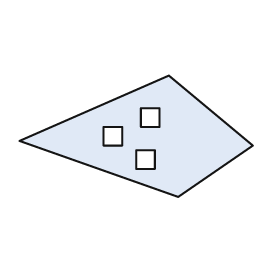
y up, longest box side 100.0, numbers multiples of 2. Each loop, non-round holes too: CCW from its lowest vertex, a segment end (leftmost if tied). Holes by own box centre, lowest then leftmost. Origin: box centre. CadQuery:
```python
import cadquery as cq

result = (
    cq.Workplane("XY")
    .moveTo(18.0, -26.0)
    .lineTo(50.0, -4.0)
    .lineTo(14.0, 26.0)
    .lineTo(-50.0, -2.0)
    .close()
    .moveTo(0.0, -14.0)
    .lineTo(8.0, -14.0)
    .lineTo(8.0, -6.0)
    .lineTo(0.0, -6.0)
    .close()
    .moveTo(-14.0, -4.0)
    .lineTo(-6.0, -4.0)
    .lineTo(-6.0, 4.0)
    .lineTo(-14.0, 4.0)
    .close()
    .moveTo(2.0, 4.0)
    .lineTo(10.0, 4.0)
    .lineTo(10.0, 12.0)
    .lineTo(2.0, 12.0)
    .close()
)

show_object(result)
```